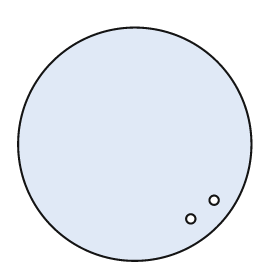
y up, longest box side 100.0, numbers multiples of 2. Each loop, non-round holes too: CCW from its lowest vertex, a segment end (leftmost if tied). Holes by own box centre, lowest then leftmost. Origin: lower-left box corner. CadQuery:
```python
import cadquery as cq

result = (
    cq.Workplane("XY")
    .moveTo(50.0, 50.0)
    .circle(50.0)
    .moveTo(74.0, 18.0)
    .circle(2.0)
    .moveTo(84.0, 26.0)
    .circle(2.0)
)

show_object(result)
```